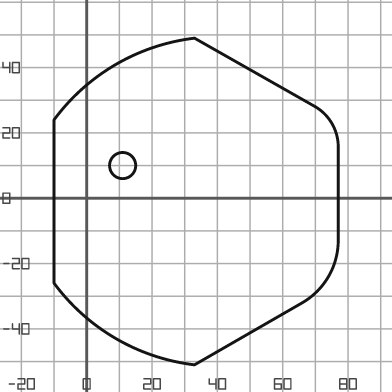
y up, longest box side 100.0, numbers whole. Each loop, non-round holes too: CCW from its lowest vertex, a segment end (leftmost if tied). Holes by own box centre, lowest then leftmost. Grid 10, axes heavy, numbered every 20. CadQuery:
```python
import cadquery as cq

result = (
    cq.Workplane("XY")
    .moveTo(33.0, -51.0)
    .lineTo(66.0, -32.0)
    .threePointArc((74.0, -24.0), (77.0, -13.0))
    .lineTo(77.0, 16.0)
    .threePointArc((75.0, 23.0), (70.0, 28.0))
    .lineTo(33.0, 49.0)
    .threePointArc((9.0, 41.0), (-10.0, 24.0))
    .lineTo(-10.0, -26.0)
    .threePointArc((9.0, -43.0), (33.0, -51.0))
    .close()
    .moveTo(11.0, 10.0)
    .circle(4.0)
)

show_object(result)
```